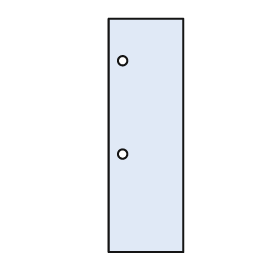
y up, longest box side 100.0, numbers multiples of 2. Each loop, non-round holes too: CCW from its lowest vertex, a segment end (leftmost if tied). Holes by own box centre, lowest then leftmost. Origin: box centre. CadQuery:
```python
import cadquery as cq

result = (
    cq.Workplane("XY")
    .moveTo(-16.0, -50.0)
    .lineTo(16.0, -50.0)
    .lineTo(16.0, 50.0)
    .lineTo(-16.0, 50.0)
    .close()
    .moveTo(-10.0, -8.0)
    .circle(2.0)
    .moveTo(-10.0, 32.0)
    .circle(2.0)
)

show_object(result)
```